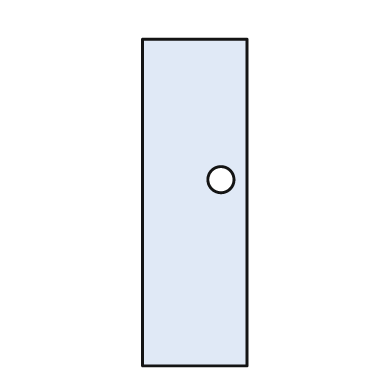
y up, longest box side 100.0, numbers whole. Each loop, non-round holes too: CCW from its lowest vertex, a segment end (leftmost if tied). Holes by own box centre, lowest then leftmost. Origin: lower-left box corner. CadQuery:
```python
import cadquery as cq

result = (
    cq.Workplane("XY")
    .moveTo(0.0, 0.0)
    .lineTo(32.0, 0.0)
    .lineTo(32.0, 100.0)
    .lineTo(0.0, 100.0)
    .close()
    .moveTo(24.0, 57.0)
    .circle(4.0)
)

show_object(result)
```